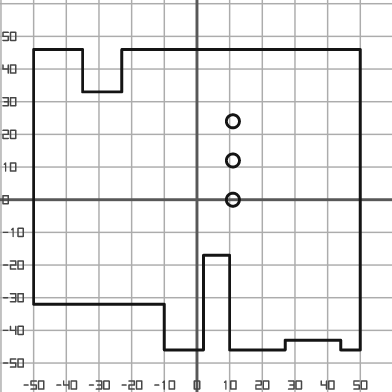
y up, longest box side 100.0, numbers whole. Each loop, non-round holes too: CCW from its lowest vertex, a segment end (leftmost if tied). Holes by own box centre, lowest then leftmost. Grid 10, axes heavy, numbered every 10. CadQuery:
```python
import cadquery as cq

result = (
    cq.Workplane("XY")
    .moveTo(-10.0, -46.0)
    .lineTo(2.0, -46.0)
    .lineTo(2.0, -17.0)
    .lineTo(10.0, -17.0)
    .lineTo(10.0, -46.0)
    .lineTo(27.0, -46.0)
    .lineTo(27.0, -43.0)
    .lineTo(44.0, -43.0)
    .lineTo(44.0, -46.0)
    .lineTo(50.0, -46.0)
    .lineTo(50.0, 46.0)
    .lineTo(-23.0, 46.0)
    .lineTo(-23.0, 33.0)
    .lineTo(-35.0, 33.0)
    .lineTo(-35.0, 46.0)
    .lineTo(-50.0, 46.0)
    .lineTo(-50.0, -32.0)
    .lineTo(-10.0, -32.0)
    .close()
    .moveTo(11.0, 0.0)
    .circle(2.0)
    .moveTo(11.0, 12.0)
    .circle(2.0)
    .moveTo(11.0, 24.0)
    .circle(2.0)
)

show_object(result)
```